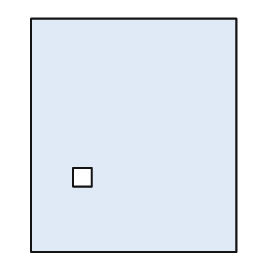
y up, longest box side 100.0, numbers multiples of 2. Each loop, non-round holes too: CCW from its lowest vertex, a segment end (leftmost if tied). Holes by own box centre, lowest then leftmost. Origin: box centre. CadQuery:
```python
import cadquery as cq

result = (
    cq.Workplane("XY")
    .moveTo(-44.0, -50.0)
    .lineTo(44.0, -50.0)
    .lineTo(44.0, 50.0)
    .lineTo(-44.0, 50.0)
    .close()
    .moveTo(-26.0, -22.0)
    .lineTo(-18.0, -22.0)
    .lineTo(-18.0, -14.0)
    .lineTo(-26.0, -14.0)
    .close()
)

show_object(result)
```